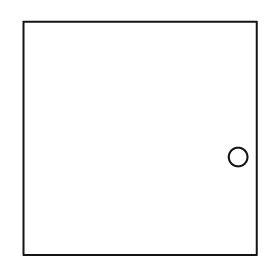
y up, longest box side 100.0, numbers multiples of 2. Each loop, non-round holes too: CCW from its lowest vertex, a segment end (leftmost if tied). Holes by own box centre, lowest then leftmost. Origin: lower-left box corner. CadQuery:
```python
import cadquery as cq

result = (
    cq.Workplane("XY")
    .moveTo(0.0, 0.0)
    .lineTo(100.0, 0.0)
    .lineTo(100.0, 100.0)
    .lineTo(0.0, 100.0)
    .close()
    .moveTo(92.0, 42.0)
    .circle(4.0)
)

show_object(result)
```